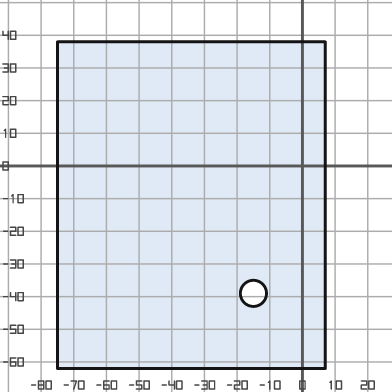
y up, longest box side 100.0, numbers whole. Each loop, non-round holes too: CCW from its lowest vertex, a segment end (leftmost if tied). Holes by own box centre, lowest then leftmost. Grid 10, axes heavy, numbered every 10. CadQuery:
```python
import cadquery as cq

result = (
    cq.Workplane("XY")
    .moveTo(-75.0, -62.0)
    .lineTo(7.0, -62.0)
    .lineTo(7.0, 38.0)
    .lineTo(-75.0, 38.0)
    .close()
    .moveTo(-15.0, -39.0)
    .circle(4.0)
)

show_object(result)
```